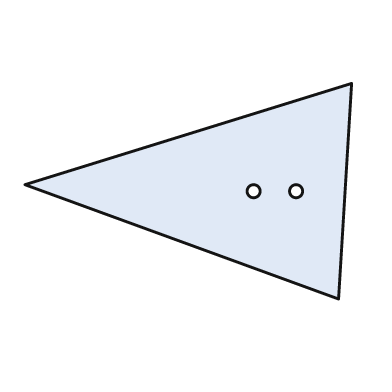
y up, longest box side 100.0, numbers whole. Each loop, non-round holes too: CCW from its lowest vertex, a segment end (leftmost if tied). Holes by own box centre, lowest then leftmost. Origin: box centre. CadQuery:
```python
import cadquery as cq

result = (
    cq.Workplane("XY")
    .moveTo(46.0, -33.0)
    .lineTo(50.0, 33.0)
    .lineTo(-50.0, 2.0)
    .close()
    .moveTo(20.0, 0.0)
    .circle(2.0)
    .moveTo(33.0, 0.0)
    .circle(2.0)
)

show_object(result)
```